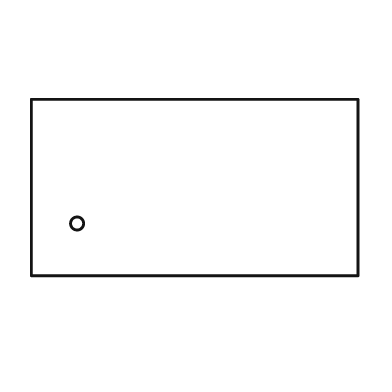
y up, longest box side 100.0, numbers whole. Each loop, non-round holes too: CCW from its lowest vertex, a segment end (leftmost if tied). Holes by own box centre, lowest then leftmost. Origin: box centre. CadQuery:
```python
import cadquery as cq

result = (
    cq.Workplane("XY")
    .moveTo(-50.0, -27.0)
    .lineTo(50.0, -27.0)
    .lineTo(50.0, 27.0)
    .lineTo(-50.0, 27.0)
    .close()
    .moveTo(-36.0, -11.0)
    .circle(2.0)
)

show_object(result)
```